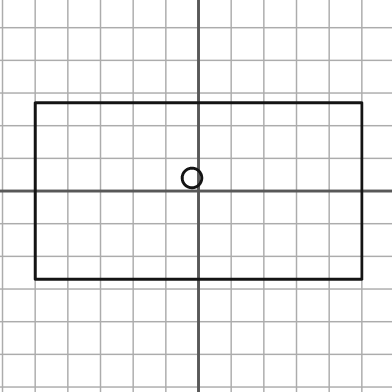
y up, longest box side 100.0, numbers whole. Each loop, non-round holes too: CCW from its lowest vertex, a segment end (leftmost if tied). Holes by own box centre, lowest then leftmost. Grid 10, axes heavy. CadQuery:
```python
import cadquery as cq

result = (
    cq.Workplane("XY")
    .moveTo(-50.0, -27.0)
    .lineTo(50.0, -27.0)
    .lineTo(50.0, 27.0)
    .lineTo(-50.0, 27.0)
    .close()
    .moveTo(-2.0, 4.0)
    .circle(3.0)
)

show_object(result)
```